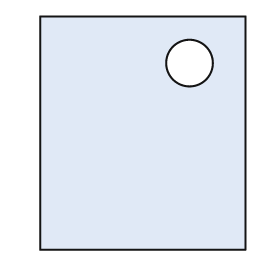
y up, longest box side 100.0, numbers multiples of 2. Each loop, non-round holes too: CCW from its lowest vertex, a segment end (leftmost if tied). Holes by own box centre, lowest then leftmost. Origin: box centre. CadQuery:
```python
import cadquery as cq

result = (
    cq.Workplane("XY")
    .moveTo(-44.0, -50.0)
    .lineTo(44.0, -50.0)
    .lineTo(44.0, 50.0)
    .lineTo(-44.0, 50.0)
    .close()
    .moveTo(20.0, 30.0)
    .circle(10.0)
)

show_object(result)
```